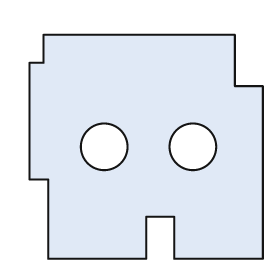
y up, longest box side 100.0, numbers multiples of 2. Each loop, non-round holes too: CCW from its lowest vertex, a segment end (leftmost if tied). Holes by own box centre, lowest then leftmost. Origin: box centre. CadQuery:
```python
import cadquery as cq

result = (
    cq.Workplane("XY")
    .moveTo(-42.0, -48.0)
    .lineTo(0.0, -48.0)
    .lineTo(0.0, -30.0)
    .lineTo(12.0, -30.0)
    .lineTo(12.0, -48.0)
    .lineTo(50.0, -48.0)
    .lineTo(50.0, 26.0)
    .lineTo(38.0, 26.0)
    .lineTo(38.0, 48.0)
    .lineTo(-44.0, 48.0)
    .lineTo(-44.0, 36.0)
    .lineTo(-50.0, 36.0)
    .lineTo(-50.0, -14.0)
    .lineTo(-42.0, -14.0)
    .close()
    .moveTo(-18.0, 0.0)
    .circle(10.0)
    .moveTo(20.0, 0.0)
    .circle(10.0)
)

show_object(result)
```